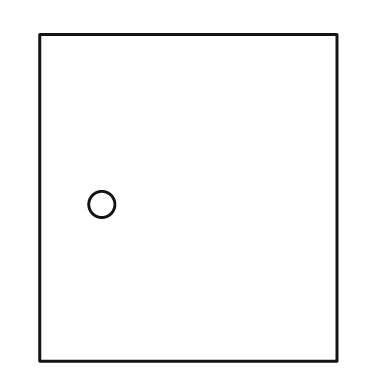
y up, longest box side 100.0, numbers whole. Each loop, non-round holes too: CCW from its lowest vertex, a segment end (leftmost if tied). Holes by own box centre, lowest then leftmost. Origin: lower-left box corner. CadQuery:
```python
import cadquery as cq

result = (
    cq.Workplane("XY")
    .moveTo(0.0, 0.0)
    .lineTo(91.0, 0.0)
    .lineTo(91.0, 100.0)
    .lineTo(0.0, 100.0)
    .close()
    .moveTo(19.0, 48.0)
    .circle(4.0)
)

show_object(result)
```